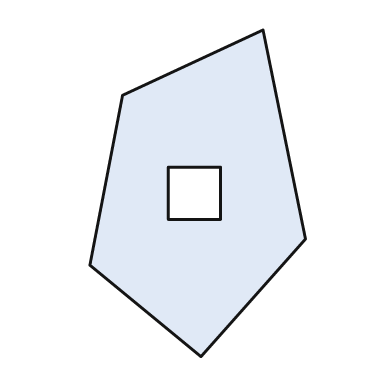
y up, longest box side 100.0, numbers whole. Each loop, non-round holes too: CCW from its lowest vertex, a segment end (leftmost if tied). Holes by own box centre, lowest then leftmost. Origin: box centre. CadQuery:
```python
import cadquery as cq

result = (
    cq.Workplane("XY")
    .moveTo(1.0, -50.0)
    .lineTo(33.0, -14.0)
    .lineTo(20.0, 50.0)
    .lineTo(-23.0, 30.0)
    .lineTo(-33.0, -22.0)
    .close()
    .moveTo(-9.0, -8.0)
    .lineTo(7.0, -8.0)
    .lineTo(7.0, 8.0)
    .lineTo(-9.0, 8.0)
    .close()
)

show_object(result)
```